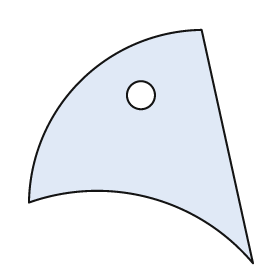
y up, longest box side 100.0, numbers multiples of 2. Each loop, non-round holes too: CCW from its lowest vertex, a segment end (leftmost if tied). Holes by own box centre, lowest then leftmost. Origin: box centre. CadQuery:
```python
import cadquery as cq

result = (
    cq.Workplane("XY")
    .moveTo(48.0, -50.0)
    .lineTo(26.0, 50.0)
    .threePointArc((-26.0, 28.0), (-48.0, -24.0))
    .threePointArc((4.0, -22.0), (48.0, -50.0))
    .close()
    .moveTo(0.0, 22.0)
    .circle(6.0)
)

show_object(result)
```